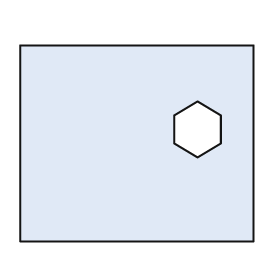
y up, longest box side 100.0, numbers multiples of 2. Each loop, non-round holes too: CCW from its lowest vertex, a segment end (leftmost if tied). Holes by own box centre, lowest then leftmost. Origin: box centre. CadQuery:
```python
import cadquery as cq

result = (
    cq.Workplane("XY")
    .moveTo(-50.0, -42.0)
    .lineTo(50.0, -42.0)
    .lineTo(50.0, 42.0)
    .lineTo(-50.0, 42.0)
    .close()
    .moveTo(26.0, -6.0)
    .lineTo(36.0, 0.0)
    .lineTo(36.0, 12.0)
    .lineTo(26.0, 18.0)
    .lineTo(16.0, 12.0)
    .lineTo(16.0, 0.0)
    .close()
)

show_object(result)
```